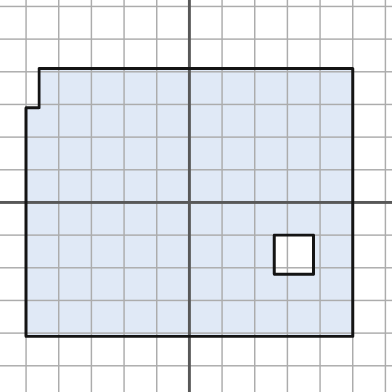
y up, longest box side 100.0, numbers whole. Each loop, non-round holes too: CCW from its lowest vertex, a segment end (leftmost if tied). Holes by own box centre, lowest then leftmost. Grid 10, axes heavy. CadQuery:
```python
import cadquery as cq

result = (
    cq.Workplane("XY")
    .moveTo(-50.0, -41.0)
    .lineTo(50.0, -41.0)
    .lineTo(50.0, 41.0)
    .lineTo(-46.0, 41.0)
    .lineTo(-46.0, 29.0)
    .lineTo(-50.0, 29.0)
    .close()
    .moveTo(26.0, -22.0)
    .lineTo(38.0, -22.0)
    .lineTo(38.0, -10.0)
    .lineTo(26.0, -10.0)
    .close()
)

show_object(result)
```